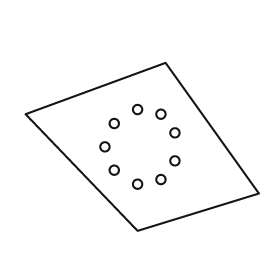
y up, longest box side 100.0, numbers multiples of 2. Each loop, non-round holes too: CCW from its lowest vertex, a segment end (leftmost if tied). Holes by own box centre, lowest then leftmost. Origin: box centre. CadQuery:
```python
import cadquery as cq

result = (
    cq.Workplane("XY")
    .moveTo(-2.0, -36.0)
    .lineTo(50.0, -20.0)
    .lineTo(10.0, 36.0)
    .lineTo(-50.0, 14.0)
    .close()
    .moveTo(-2.0, -16.0)
    .circle(2.0)
    .moveTo(8.0, -14.0)
    .circle(2.0)
    .moveTo(-12.0, -10.0)
    .circle(2.0)
    .moveTo(14.0, -6.0)
    .circle(2.0)
    .moveTo(-16.0, 0.0)
    .circle(2.0)
    .moveTo(14.0, 6.0)
    .circle(2.0)
    .moveTo(-12.0, 10.0)
    .circle(2.0)
    .moveTo(8.0, 14.0)
    .circle(2.0)
    .moveTo(-2.0, 16.0)
    .circle(2.0)
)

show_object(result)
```